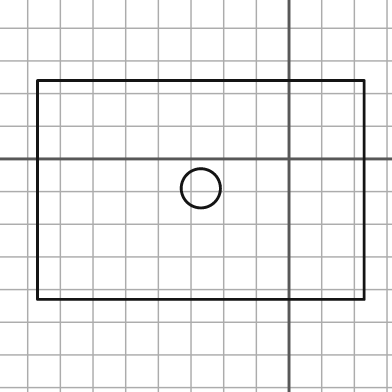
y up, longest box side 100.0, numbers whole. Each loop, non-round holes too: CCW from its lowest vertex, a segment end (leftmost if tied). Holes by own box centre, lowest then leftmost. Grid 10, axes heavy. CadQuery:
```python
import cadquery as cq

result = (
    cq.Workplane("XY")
    .moveTo(-77.0, -43.0)
    .lineTo(23.0, -43.0)
    .lineTo(23.0, 24.0)
    .lineTo(-77.0, 24.0)
    .close()
    .moveTo(-27.0, -9.0)
    .circle(6.0)
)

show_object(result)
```